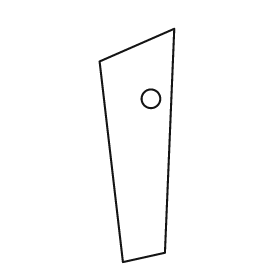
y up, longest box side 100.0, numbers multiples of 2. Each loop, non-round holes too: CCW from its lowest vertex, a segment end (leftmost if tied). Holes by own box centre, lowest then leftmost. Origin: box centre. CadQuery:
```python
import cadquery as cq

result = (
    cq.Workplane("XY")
    .moveTo(-6.0, -50.0)
    .lineTo(12.0, -46.0)
    .lineTo(16.0, 50.0)
    .lineTo(-16.0, 36.0)
    .close()
    .moveTo(6.0, 20.0)
    .circle(4.0)
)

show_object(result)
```